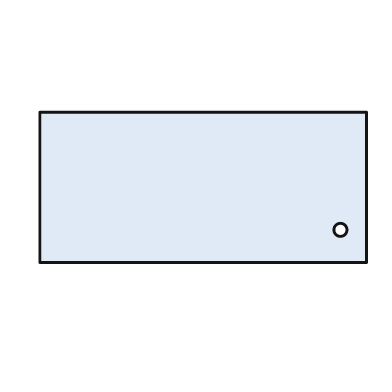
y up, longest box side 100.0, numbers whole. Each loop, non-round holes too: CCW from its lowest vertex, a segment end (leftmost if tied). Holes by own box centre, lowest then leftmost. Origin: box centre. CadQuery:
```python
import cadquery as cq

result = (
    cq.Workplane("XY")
    .moveTo(-50.0, -23.0)
    .lineTo(50.0, -23.0)
    .lineTo(50.0, 23.0)
    .lineTo(-50.0, 23.0)
    .close()
    .moveTo(42.0, -13.0)
    .circle(2.0)
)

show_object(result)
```